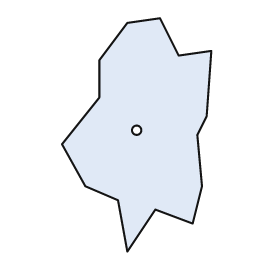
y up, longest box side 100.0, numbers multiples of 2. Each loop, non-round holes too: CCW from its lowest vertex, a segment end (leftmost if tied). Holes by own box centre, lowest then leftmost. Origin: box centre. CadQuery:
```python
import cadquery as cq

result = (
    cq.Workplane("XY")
    .moveTo(-4.0, -50.0)
    .lineTo(8.0, -32.0)
    .lineTo(24.0, -38.0)
    .lineTo(28.0, -22.0)
    .lineTo(26.0, 0.0)
    .lineTo(30.0, 8.0)
    .lineTo(32.0, 36.0)
    .lineTo(18.0, 34.0)
    .lineTo(10.0, 50.0)
    .lineTo(-4.0, 48.0)
    .lineTo(-16.0, 32.0)
    .lineTo(-16.0, 16.0)
    .lineTo(-32.0, -4.0)
    .lineTo(-22.0, -22.0)
    .lineTo(-8.0, -28.0)
    .close()
    .moveTo(0.0, 2.0)
    .circle(2.0)
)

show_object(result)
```